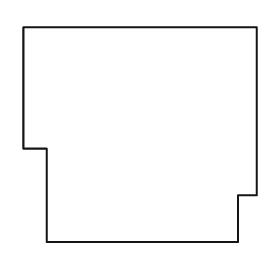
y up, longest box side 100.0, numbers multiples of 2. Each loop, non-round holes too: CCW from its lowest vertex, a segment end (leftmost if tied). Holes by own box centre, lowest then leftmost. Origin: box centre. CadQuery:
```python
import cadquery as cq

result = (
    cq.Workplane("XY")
    .moveTo(-40.0, -46.0)
    .lineTo(42.0, -46.0)
    .lineTo(42.0, -26.0)
    .lineTo(50.0, -26.0)
    .lineTo(50.0, 46.0)
    .lineTo(-50.0, 46.0)
    .lineTo(-50.0, -6.0)
    .lineTo(-40.0, -6.0)
    .close()
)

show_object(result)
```